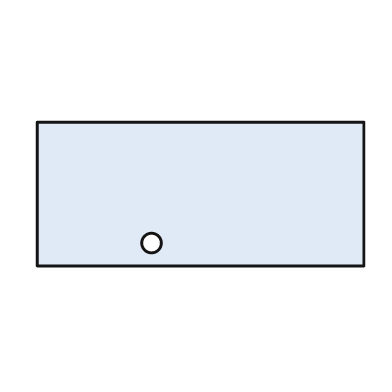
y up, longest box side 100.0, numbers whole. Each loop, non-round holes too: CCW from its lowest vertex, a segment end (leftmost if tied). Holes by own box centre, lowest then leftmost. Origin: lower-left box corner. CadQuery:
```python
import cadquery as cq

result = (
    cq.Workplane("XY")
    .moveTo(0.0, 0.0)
    .lineTo(100.0, 0.0)
    .lineTo(100.0, 44.0)
    .lineTo(0.0, 44.0)
    .close()
    .moveTo(35.0, 7.0)
    .circle(3.0)
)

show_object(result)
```